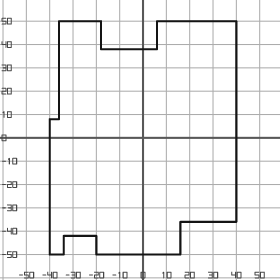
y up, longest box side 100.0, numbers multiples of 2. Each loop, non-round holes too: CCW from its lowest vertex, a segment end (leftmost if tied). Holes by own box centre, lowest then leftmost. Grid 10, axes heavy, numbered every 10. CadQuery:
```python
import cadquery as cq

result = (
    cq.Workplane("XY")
    .moveTo(-40.0, -50.0)
    .lineTo(-34.0, -50.0)
    .lineTo(-34.0, -42.0)
    .lineTo(-20.0, -42.0)
    .lineTo(-20.0, -50.0)
    .lineTo(16.0, -50.0)
    .lineTo(16.0, -36.0)
    .lineTo(40.0, -36.0)
    .lineTo(40.0, 50.0)
    .lineTo(6.0, 50.0)
    .lineTo(6.0, 38.0)
    .lineTo(-18.0, 38.0)
    .lineTo(-18.0, 50.0)
    .lineTo(-36.0, 50.0)
    .lineTo(-36.0, 8.0)
    .lineTo(-40.0, 8.0)
    .close()
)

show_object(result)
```